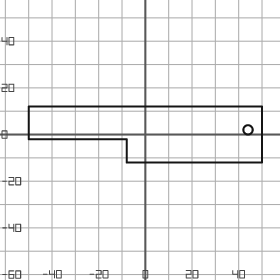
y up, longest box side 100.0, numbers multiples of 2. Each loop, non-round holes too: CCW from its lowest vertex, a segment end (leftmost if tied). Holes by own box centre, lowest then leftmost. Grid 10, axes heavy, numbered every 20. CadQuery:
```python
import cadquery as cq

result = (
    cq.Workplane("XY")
    .moveTo(-8.0, -12.0)
    .lineTo(50.0, -12.0)
    .lineTo(50.0, 12.0)
    .lineTo(-50.0, 12.0)
    .lineTo(-50.0, -2.0)
    .lineTo(-8.0, -2.0)
    .close()
    .moveTo(44.0, 2.0)
    .circle(2.0)
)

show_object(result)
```